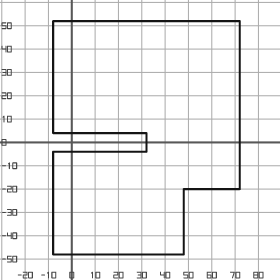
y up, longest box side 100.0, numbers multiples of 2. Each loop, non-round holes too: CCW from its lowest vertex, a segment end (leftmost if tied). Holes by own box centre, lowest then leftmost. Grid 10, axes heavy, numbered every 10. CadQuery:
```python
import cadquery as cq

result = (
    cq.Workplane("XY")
    .moveTo(-8.0, -48.0)
    .lineTo(48.0, -48.0)
    .lineTo(48.0, -20.0)
    .lineTo(72.0, -20.0)
    .lineTo(72.0, 52.0)
    .lineTo(-8.0, 52.0)
    .lineTo(-8.0, 4.0)
    .lineTo(32.0, 4.0)
    .lineTo(32.0, -4.0)
    .lineTo(-8.0, -4.0)
    .close()
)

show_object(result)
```